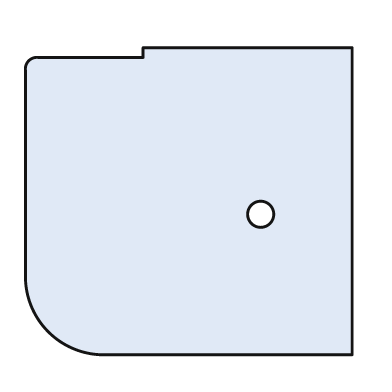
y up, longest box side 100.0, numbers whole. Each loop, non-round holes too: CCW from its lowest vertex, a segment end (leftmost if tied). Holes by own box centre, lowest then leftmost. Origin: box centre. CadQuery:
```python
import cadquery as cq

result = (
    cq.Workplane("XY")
    .moveTo(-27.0, -47.0)
    .lineTo(50.0, -47.0)
    .lineTo(50.0, 47.0)
    .lineTo(-14.0, 47.0)
    .lineTo(-14.0, 44.0)
    .lineTo(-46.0, 44.0)
    .threePointArc((-49.0, 43.0), (-50.0, 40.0))
    .lineTo(-50.0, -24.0)
    .threePointArc((-43.0, -40.0), (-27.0, -47.0))
    .close()
    .moveTo(22.0, -4.0)
    .circle(4.0)
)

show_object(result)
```